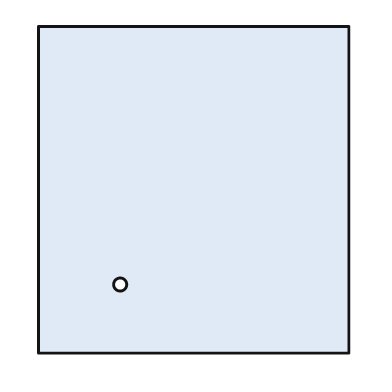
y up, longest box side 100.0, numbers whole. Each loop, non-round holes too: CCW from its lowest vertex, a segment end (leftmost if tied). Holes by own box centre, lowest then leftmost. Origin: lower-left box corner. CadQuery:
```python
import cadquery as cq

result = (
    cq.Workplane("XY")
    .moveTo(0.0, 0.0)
    .lineTo(95.0, 0.0)
    .lineTo(95.0, 100.0)
    .lineTo(0.0, 100.0)
    .close()
    .moveTo(25.0, 21.0)
    .circle(2.0)
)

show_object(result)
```